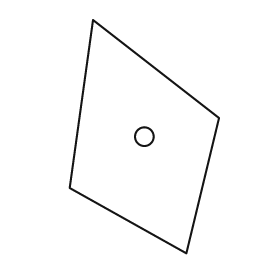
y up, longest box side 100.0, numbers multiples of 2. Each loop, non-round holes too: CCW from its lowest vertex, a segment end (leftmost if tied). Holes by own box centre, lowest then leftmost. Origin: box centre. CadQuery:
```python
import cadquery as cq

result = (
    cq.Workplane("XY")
    .moveTo(18.0, -50.0)
    .lineTo(32.0, 8.0)
    .lineTo(-22.0, 50.0)
    .lineTo(-32.0, -22.0)
    .close()
    .moveTo(0.0, 0.0)
    .circle(4.0)
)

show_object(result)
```